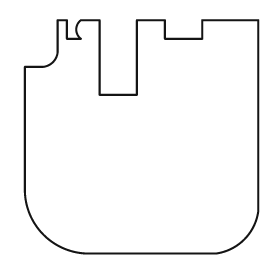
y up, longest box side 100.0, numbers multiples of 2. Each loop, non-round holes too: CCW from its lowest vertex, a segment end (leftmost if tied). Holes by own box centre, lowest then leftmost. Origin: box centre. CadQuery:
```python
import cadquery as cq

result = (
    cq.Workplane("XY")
    .moveTo(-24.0, -50.0)
    .lineTo(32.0, -50.0)
    .threePointArc((44.0, -44.0), (50.0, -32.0))
    .lineTo(50.0, 50.0)
    .lineTo(26.0, 50.0)
    .lineTo(26.0, 42.0)
    .lineTo(10.0, 42.0)
    .lineTo(10.0, 50.0)
    .lineTo(-2.0, 50.0)
    .lineTo(-2.0, 18.0)
    .lineTo(-18.0, 18.0)
    .lineTo(-18.0, 50.0)
    .lineTo(-26.0, 50.0)
    .threePointArc((-28.0, 46.0), (-26.0, 42.0))
    .lineTo(-32.0, 42.0)
    .lineTo(-32.0, 50.0)
    .lineTo(-36.0, 50.0)
    .lineTo(-36.0, 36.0)
    .threePointArc((-38.0, 32.0), (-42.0, 30.0))
    .lineTo(-50.0, 30.0)
    .lineTo(-50.0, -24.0)
    .threePointArc((-42.0, -42.0), (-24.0, -50.0))
    .close()
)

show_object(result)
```